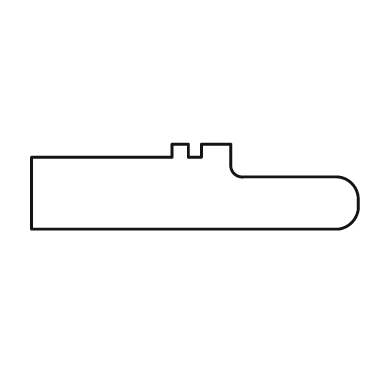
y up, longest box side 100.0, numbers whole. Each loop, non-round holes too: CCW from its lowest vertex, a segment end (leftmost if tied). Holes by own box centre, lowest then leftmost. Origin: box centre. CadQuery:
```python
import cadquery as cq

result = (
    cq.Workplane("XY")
    .moveTo(-50.0, -13.0)
    .lineTo(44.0, -13.0)
    .threePointArc((48.0, -11.0), (50.0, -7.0))
    .lineTo(50.0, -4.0)
    .threePointArc((48.0, 1.0), (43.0, 3.0))
    .lineTo(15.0, 3.0)
    .threePointArc((12.0, 4.0), (11.0, 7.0))
    .lineTo(11.0, 13.0)
    .lineTo(2.0, 13.0)
    .lineTo(2.0, 9.0)
    .lineTo(-2.0, 9.0)
    .lineTo(-2.0, 13.0)
    .lineTo(-7.0, 13.0)
    .lineTo(-7.0, 9.0)
    .lineTo(-50.0, 9.0)
    .close()
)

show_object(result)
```